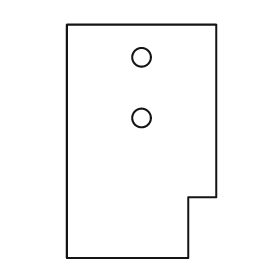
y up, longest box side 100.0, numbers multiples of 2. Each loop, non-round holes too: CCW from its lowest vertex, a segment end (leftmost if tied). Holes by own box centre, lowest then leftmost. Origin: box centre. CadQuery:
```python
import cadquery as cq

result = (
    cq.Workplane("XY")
    .moveTo(-32.0, -50.0)
    .lineTo(20.0, -50.0)
    .lineTo(20.0, -24.0)
    .lineTo(32.0, -24.0)
    .lineTo(32.0, 50.0)
    .lineTo(-32.0, 50.0)
    .close()
    .moveTo(0.0, 10.0)
    .circle(4.0)
    .moveTo(0.0, 36.0)
    .circle(4.0)
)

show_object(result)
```